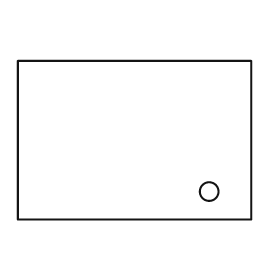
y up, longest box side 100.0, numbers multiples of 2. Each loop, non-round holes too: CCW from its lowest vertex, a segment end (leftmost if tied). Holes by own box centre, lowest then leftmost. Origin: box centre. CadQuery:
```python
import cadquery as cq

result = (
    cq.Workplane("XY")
    .moveTo(-50.0, -34.0)
    .lineTo(50.0, -34.0)
    .lineTo(50.0, 34.0)
    .lineTo(-50.0, 34.0)
    .close()
    .moveTo(32.0, -22.0)
    .circle(4.0)
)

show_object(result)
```